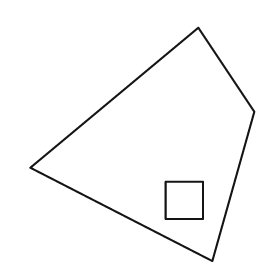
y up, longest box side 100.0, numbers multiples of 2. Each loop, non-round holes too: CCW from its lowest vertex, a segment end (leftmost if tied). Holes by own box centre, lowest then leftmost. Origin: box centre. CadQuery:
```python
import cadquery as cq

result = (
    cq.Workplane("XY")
    .moveTo(30.0, -50.0)
    .lineTo(48.0, 14.0)
    .lineTo(24.0, 50.0)
    .lineTo(-48.0, -10.0)
    .close()
    .moveTo(10.0, -32.0)
    .lineTo(26.0, -32.0)
    .lineTo(26.0, -16.0)
    .lineTo(10.0, -16.0)
    .close()
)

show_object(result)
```